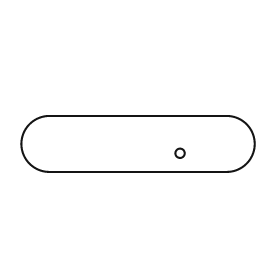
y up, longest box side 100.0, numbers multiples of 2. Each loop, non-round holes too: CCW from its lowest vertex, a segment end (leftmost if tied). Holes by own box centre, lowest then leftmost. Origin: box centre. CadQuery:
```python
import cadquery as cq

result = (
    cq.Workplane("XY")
    .moveTo(-38.0, -12.0)
    .lineTo(38.0, -12.0)
    .threePointArc((50.0, 0.0), (38.0, 12.0))
    .lineTo(-38.0, 12.0)
    .threePointArc((-50.0, 0.0), (-38.0, -12.0))
    .close()
    .moveTo(18.0, -4.0)
    .circle(2.0)
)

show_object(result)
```